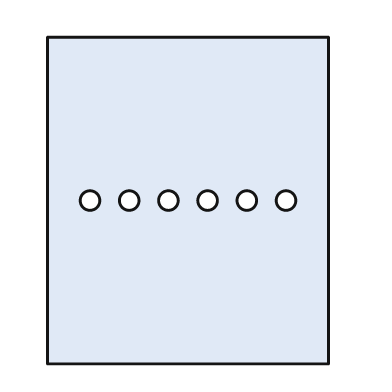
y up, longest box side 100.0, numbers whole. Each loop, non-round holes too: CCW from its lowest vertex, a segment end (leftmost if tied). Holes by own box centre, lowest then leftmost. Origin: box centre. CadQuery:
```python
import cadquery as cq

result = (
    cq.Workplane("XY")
    .moveTo(-43.0, -50.0)
    .lineTo(43.0, -50.0)
    .lineTo(43.0, 50.0)
    .lineTo(-43.0, 50.0)
    .close()
    .moveTo(-30.0, 0.0)
    .circle(3.0)
    .moveTo(-18.0, 0.0)
    .circle(3.0)
    .moveTo(-6.0, 0.0)
    .circle(3.0)
    .moveTo(6.0, 0.0)
    .circle(3.0)
    .moveTo(18.0, 0.0)
    .circle(3.0)
    .moveTo(30.0, 0.0)
    .circle(3.0)
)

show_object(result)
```